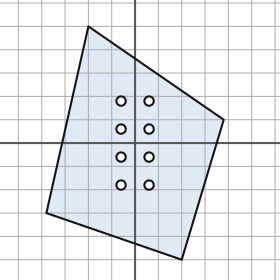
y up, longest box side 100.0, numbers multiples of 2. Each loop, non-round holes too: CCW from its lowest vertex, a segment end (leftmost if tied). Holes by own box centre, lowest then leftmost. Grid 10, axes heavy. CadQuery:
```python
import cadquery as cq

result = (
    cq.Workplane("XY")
    .moveTo(20.0, -50.0)
    .lineTo(38.0, 10.0)
    .lineTo(-20.0, 50.0)
    .lineTo(-38.0, -30.0)
    .close()
    .moveTo(-6.0, -18.0)
    .circle(2.0)
    .moveTo(6.0, -18.0)
    .circle(2.0)
    .moveTo(-6.0, -6.0)
    .circle(2.0)
    .moveTo(6.0, -6.0)
    .circle(2.0)
    .moveTo(-6.0, 6.0)
    .circle(2.0)
    .moveTo(6.0, 6.0)
    .circle(2.0)
    .moveTo(-6.0, 18.0)
    .circle(2.0)
    .moveTo(6.0, 18.0)
    .circle(2.0)
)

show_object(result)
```